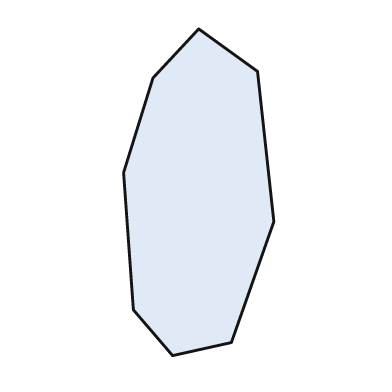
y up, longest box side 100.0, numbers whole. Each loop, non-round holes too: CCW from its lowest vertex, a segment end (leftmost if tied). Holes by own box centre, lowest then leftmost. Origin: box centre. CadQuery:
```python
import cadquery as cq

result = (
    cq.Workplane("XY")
    .moveTo(-8.0, -50.0)
    .lineTo(10.0, -46.0)
    .lineTo(23.0, -9.0)
    .lineTo(18.0, 37.0)
    .lineTo(0.0, 50.0)
    .lineTo(-14.0, 35.0)
    .lineTo(-23.0, 6.0)
    .lineTo(-20.0, -36.0)
    .close()
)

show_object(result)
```